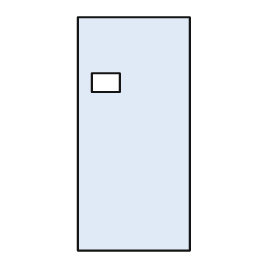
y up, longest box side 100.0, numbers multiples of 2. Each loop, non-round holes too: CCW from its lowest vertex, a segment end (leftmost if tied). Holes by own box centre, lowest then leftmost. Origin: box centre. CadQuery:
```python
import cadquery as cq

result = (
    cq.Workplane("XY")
    .moveTo(-24.0, -50.0)
    .lineTo(24.0, -50.0)
    .lineTo(24.0, 50.0)
    .lineTo(-24.0, 50.0)
    .close()
    .moveTo(-18.0, 18.0)
    .lineTo(-6.0, 18.0)
    .lineTo(-6.0, 26.0)
    .lineTo(-18.0, 26.0)
    .close()
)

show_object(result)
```